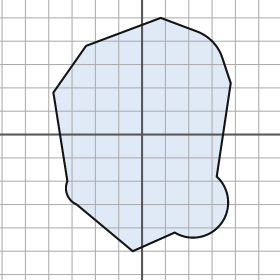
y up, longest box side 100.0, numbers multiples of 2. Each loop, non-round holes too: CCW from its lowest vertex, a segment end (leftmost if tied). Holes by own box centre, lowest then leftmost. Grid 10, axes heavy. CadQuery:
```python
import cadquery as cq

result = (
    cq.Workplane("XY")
    .moveTo(-4.0, -50.0)
    .lineTo(14.0, -42.0)
    .threePointArc((34.0, -38.0), (32.0, -18.0))
    .lineTo(38.0, 22.0)
    .lineTo(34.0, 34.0)
    .threePointArc((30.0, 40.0), (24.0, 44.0))
    .lineTo(8.0, 50.0)
    .lineTo(-24.0, 38.0)
    .lineTo(-38.0, 18.0)
    .lineTo(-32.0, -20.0)
    .threePointArc((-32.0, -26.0), (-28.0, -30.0))
    .close()
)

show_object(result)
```